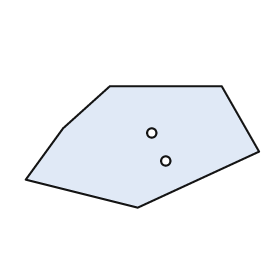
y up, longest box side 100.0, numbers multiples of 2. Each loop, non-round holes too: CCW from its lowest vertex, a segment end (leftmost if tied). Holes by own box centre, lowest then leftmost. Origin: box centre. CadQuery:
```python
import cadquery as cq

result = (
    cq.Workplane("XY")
    .moveTo(-2.0, -26.0)
    .lineTo(50.0, -2.0)
    .lineTo(34.0, 26.0)
    .lineTo(-14.0, 26.0)
    .lineTo(-34.0, 8.0)
    .lineTo(-50.0, -14.0)
    .close()
    .moveTo(10.0, -6.0)
    .circle(2.0)
    .moveTo(4.0, 6.0)
    .circle(2.0)
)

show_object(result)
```